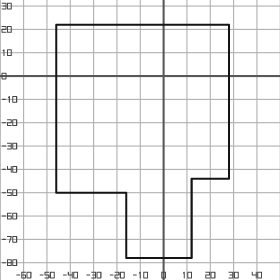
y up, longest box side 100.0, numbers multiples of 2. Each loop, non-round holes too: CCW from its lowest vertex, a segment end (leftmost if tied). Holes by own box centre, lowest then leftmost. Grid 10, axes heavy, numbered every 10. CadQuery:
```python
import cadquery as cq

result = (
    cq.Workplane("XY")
    .moveTo(-16.0, -78.0)
    .lineTo(12.0, -78.0)
    .lineTo(12.0, -44.0)
    .lineTo(28.0, -44.0)
    .lineTo(28.0, 22.0)
    .lineTo(-46.0, 22.0)
    .lineTo(-46.0, -50.0)
    .lineTo(-16.0, -50.0)
    .close()
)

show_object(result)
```